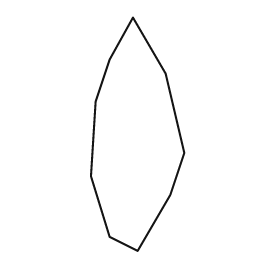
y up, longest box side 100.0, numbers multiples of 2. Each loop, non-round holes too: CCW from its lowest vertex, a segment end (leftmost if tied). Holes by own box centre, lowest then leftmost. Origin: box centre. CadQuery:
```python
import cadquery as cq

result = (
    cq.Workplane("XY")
    .moveTo(0.0, -50.0)
    .lineTo(14.0, -26.0)
    .lineTo(20.0, -8.0)
    .lineTo(12.0, 26.0)
    .lineTo(-2.0, 50.0)
    .lineTo(-12.0, 32.0)
    .lineTo(-18.0, 14.0)
    .lineTo(-20.0, -18.0)
    .lineTo(-12.0, -44.0)
    .close()
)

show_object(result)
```